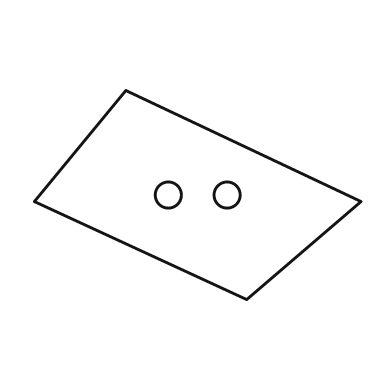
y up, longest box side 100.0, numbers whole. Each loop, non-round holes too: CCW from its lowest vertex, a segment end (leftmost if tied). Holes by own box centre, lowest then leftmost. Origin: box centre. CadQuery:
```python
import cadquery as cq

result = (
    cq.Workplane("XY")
    .moveTo(15.0, -32.0)
    .lineTo(50.0, -2.0)
    .lineTo(-22.0, 32.0)
    .lineTo(-50.0, -2.0)
    .close()
    .moveTo(-9.0, 0.0)
    .circle(4.0)
    .moveTo(9.0, 0.0)
    .circle(4.0)
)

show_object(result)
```